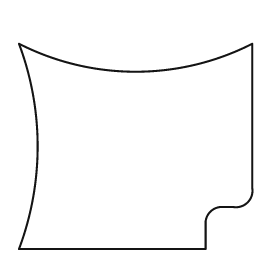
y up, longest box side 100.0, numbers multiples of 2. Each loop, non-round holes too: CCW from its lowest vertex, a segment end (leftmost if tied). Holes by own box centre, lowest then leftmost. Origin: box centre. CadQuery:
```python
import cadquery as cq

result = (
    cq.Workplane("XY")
    .moveTo(-50.0, -44.0)
    .lineTo(30.0, -44.0)
    .lineTo(30.0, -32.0)
    .threePointArc((32.0, -28.0), (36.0, -26.0))
    .lineTo(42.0, -26.0)
    .threePointArc((48.0, -24.0), (50.0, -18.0))
    .lineTo(50.0, 44.0)
    .threePointArc((0.0, 32.0), (-50.0, 44.0))
    .threePointArc((-42.0, 0.0), (-50.0, -44.0))
    .close()
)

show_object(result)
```